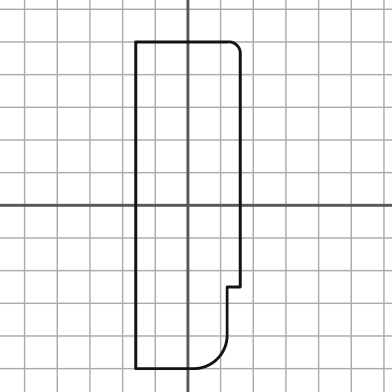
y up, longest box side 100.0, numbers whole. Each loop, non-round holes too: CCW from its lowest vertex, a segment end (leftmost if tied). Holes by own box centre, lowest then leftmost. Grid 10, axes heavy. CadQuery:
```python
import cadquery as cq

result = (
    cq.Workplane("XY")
    .moveTo(-16.0, -50.0)
    .lineTo(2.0, -50.0)
    .threePointArc((9.0, -47.0), (12.0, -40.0))
    .lineTo(12.0, -25.0)
    .lineTo(16.0, -25.0)
    .lineTo(16.0, 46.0)
    .threePointArc((15.0, 49.0), (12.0, 50.0))
    .lineTo(-16.0, 50.0)
    .close()
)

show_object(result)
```